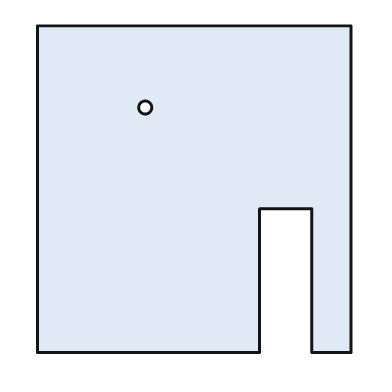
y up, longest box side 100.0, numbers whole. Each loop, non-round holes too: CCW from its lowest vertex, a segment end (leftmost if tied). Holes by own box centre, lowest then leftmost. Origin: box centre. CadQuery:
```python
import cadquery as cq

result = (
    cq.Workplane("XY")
    .moveTo(-48.0, -50.0)
    .lineTo(20.0, -50.0)
    .lineTo(20.0, -6.0)
    .lineTo(36.0, -6.0)
    .lineTo(36.0, -50.0)
    .lineTo(48.0, -50.0)
    .lineTo(48.0, 50.0)
    .lineTo(-48.0, 50.0)
    .close()
    .moveTo(-15.0, 25.0)
    .circle(2.0)
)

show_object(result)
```